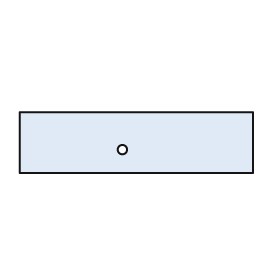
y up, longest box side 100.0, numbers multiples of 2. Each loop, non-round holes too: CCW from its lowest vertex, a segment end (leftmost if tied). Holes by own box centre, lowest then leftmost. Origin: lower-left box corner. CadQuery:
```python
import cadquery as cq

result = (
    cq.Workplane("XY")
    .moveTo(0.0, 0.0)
    .lineTo(100.0, 0.0)
    .lineTo(100.0, 26.0)
    .lineTo(0.0, 26.0)
    .close()
    .moveTo(44.0, 10.0)
    .circle(2.0)
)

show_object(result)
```